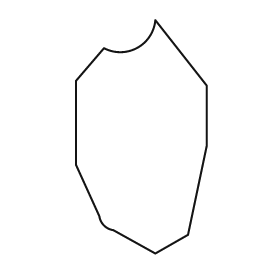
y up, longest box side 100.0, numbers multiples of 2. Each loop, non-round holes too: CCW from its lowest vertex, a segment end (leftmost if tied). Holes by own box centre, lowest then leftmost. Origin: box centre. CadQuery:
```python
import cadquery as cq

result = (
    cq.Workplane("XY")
    .moveTo(6.0, -50.0)
    .lineTo(20.0, -42.0)
    .lineTo(28.0, -4.0)
    .lineTo(28.0, 22.0)
    .lineTo(6.0, 50.0)
    .threePointArc((-2.0, 38.0), (-16.0, 38.0))
    .lineTo(-28.0, 24.0)
    .lineTo(-28.0, -12.0)
    .lineTo(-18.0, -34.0)
    .threePointArc((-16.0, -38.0), (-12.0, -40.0))
    .close()
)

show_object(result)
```